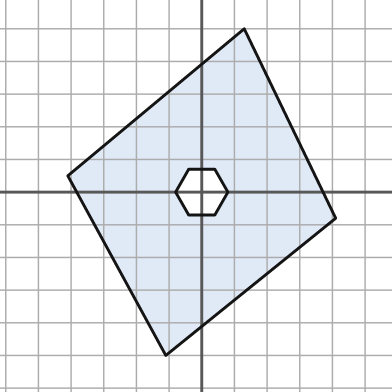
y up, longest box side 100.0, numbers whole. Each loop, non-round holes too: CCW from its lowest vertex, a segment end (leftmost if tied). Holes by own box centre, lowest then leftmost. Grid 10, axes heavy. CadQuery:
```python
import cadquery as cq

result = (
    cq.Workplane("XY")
    .moveTo(-11.0, -50.0)
    .lineTo(41.0, -8.0)
    .lineTo(13.0, 50.0)
    .lineTo(-41.0, 5.0)
    .close()
    .moveTo(-4.0, -7.0)
    .lineTo(4.0, -7.0)
    .lineTo(8.0, 0.0)
    .lineTo(4.0, 7.0)
    .lineTo(-4.0, 7.0)
    .lineTo(-8.0, 0.0)
    .close()
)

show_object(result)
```